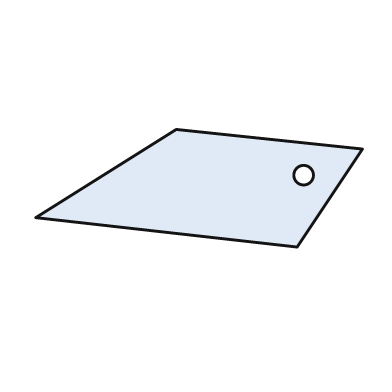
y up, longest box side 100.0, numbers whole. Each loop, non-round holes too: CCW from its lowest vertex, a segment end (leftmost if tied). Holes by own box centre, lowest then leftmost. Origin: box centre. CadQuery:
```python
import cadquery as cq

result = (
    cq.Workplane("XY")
    .moveTo(30.0, -18.0)
    .lineTo(50.0, 12.0)
    .lineTo(-7.0, 18.0)
    .lineTo(-50.0, -9.0)
    .close()
    .moveTo(32.0, 4.0)
    .circle(3.0)
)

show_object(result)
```